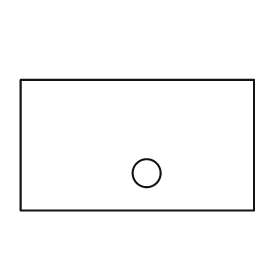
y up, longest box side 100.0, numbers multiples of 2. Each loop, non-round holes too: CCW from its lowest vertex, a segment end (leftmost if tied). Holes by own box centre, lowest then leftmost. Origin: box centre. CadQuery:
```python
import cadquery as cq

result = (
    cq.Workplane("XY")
    .moveTo(-50.0, -28.0)
    .lineTo(50.0, -28.0)
    .lineTo(50.0, 28.0)
    .lineTo(-50.0, 28.0)
    .close()
    .moveTo(4.0, -12.0)
    .circle(6.0)
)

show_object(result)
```